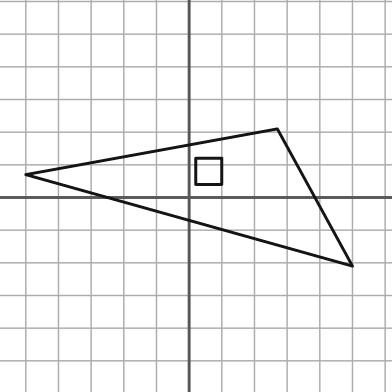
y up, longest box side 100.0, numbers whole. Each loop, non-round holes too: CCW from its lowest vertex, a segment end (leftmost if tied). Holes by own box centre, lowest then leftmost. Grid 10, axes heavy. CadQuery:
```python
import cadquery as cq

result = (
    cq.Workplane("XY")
    .moveTo(50.0, -21.0)
    .lineTo(27.0, 21.0)
    .lineTo(-50.0, 7.0)
    .close()
    .moveTo(2.0, 4.0)
    .lineTo(10.0, 4.0)
    .lineTo(10.0, 12.0)
    .lineTo(2.0, 12.0)
    .close()
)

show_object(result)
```